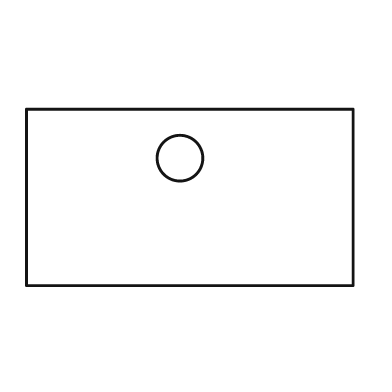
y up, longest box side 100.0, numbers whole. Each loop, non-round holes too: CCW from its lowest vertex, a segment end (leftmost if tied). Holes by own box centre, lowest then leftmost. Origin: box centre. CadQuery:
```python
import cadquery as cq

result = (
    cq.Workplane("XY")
    .moveTo(-50.0, -27.0)
    .lineTo(50.0, -27.0)
    .lineTo(50.0, 27.0)
    .lineTo(-50.0, 27.0)
    .close()
    .moveTo(-3.0, 12.0)
    .circle(7.0)
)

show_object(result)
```